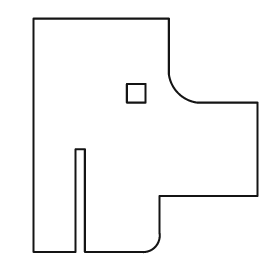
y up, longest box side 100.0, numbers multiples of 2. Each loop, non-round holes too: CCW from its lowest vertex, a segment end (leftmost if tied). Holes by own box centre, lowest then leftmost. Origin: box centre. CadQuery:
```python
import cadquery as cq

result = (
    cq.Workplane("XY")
    .moveTo(-48.0, -50.0)
    .lineTo(-30.0, -50.0)
    .lineTo(-30.0, -6.0)
    .lineTo(-26.0, -6.0)
    .lineTo(-26.0, -50.0)
    .lineTo(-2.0, -50.0)
    .threePointArc((4.0, -48.0), (6.0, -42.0))
    .lineTo(6.0, -26.0)
    .lineTo(48.0, -26.0)
    .lineTo(48.0, 14.0)
    .lineTo(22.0, 14.0)
    .threePointArc((14.0, 18.0), (10.0, 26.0))
    .lineTo(10.0, 50.0)
    .lineTo(-48.0, 50.0)
    .close()
    .moveTo(-8.0, 14.0)
    .lineTo(0.0, 14.0)
    .lineTo(0.0, 22.0)
    .lineTo(-8.0, 22.0)
    .close()
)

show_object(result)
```